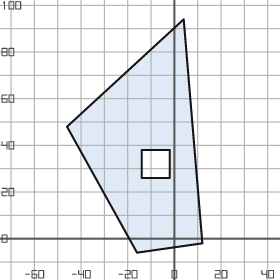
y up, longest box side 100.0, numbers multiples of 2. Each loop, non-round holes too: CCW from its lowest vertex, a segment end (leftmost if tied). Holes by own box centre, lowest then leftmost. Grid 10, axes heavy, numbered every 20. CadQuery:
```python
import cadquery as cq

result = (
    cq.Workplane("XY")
    .moveTo(-16.0, -6.0)
    .lineTo(12.0, -2.0)
    .lineTo(4.0, 94.0)
    .lineTo(-46.0, 48.0)
    .close()
    .moveTo(-14.0, 26.0)
    .lineTo(-2.0, 26.0)
    .lineTo(-2.0, 38.0)
    .lineTo(-14.0, 38.0)
    .close()
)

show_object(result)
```